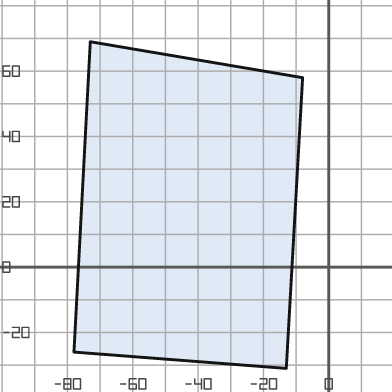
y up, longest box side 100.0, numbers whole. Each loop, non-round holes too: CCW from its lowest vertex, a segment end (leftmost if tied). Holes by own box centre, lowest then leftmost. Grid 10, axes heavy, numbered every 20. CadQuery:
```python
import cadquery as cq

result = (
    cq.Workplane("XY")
    .moveTo(-13.0, -31.0)
    .lineTo(-8.0, 58.0)
    .lineTo(-73.0, 69.0)
    .lineTo(-78.0, -26.0)
    .close()
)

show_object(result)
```